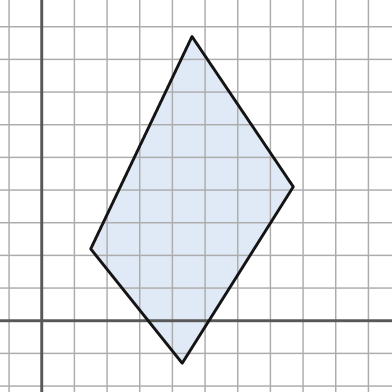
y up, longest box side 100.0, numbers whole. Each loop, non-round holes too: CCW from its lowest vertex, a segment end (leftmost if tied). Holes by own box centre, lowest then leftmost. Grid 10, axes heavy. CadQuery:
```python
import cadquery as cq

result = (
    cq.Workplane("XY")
    .moveTo(43.0, -13.0)
    .lineTo(77.0, 41.0)
    .lineTo(46.0, 87.0)
    .lineTo(15.0, 22.0)
    .close()
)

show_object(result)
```